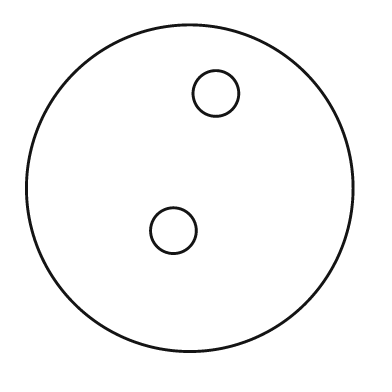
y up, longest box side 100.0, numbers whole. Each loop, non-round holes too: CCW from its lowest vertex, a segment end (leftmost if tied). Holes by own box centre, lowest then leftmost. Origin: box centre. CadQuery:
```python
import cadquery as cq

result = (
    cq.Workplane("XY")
    .moveTo(0.0, 0.0)
    .circle(50.0)
    .moveTo(-5.0, -13.0)
    .circle(7.0)
    .moveTo(8.0, 29.0)
    .circle(7.0)
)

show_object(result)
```